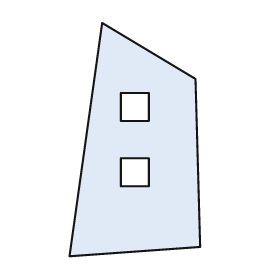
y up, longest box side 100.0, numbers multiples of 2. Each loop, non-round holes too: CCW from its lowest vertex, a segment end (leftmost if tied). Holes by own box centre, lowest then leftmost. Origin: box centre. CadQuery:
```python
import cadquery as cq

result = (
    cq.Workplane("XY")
    .moveTo(-28.0, -50.0)
    .lineTo(28.0, -46.0)
    .lineTo(26.0, 26.0)
    .lineTo(-14.0, 50.0)
    .close()
    .moveTo(-6.0, -20.0)
    .lineTo(6.0, -20.0)
    .lineTo(6.0, -8.0)
    .lineTo(-6.0, -8.0)
    .close()
    .moveTo(-6.0, 8.0)
    .lineTo(6.0, 8.0)
    .lineTo(6.0, 20.0)
    .lineTo(-6.0, 20.0)
    .close()
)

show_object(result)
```